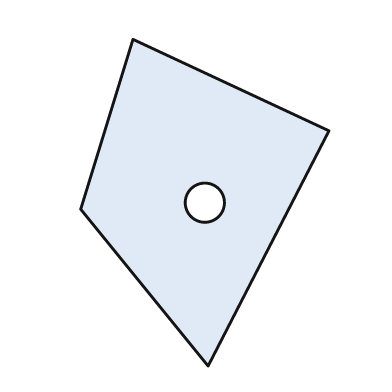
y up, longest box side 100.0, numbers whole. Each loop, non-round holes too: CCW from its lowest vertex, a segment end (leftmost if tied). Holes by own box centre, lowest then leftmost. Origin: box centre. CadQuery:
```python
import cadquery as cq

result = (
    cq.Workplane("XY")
    .moveTo(1.0, -50.0)
    .lineTo(38.0, 22.0)
    .lineTo(-22.0, 50.0)
    .lineTo(-38.0, -2.0)
    .close()
    .moveTo(0.0, 0.0)
    .circle(6.0)
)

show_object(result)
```